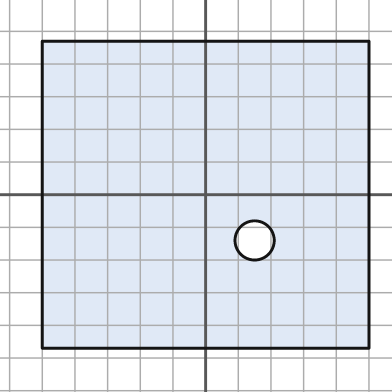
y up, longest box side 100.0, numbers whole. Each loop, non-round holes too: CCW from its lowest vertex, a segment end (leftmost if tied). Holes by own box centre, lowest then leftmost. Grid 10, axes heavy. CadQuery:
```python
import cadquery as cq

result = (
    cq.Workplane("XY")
    .moveTo(-50.0, -47.0)
    .lineTo(50.0, -47.0)
    .lineTo(50.0, 47.0)
    .lineTo(-50.0, 47.0)
    .close()
    .moveTo(15.0, -14.0)
    .circle(6.0)
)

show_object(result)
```